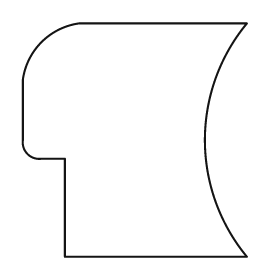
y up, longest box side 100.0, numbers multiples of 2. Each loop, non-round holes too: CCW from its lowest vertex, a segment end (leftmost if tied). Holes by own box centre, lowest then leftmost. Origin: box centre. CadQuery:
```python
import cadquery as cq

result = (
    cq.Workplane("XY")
    .moveTo(-30.0, -50.0)
    .lineTo(48.0, -50.0)
    .threePointArc((30.0, 0.0), (48.0, 50.0))
    .lineTo(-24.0, 50.0)
    .threePointArc((-40.0, 42.0), (-48.0, 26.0))
    .lineTo(-48.0, 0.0)
    .threePointArc((-46.0, -6.0), (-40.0, -8.0))
    .lineTo(-30.0, -8.0)
    .close()
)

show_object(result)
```